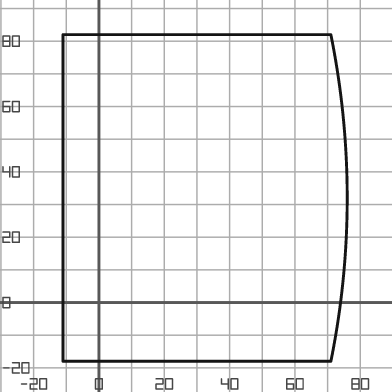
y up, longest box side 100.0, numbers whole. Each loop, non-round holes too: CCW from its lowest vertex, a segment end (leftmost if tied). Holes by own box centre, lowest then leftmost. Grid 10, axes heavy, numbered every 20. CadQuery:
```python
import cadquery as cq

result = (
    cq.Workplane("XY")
    .moveTo(-11.0, -18.0)
    .lineTo(71.0, -18.0)
    .threePointArc((76.0, 32.0), (71.0, 82.0))
    .lineTo(-11.0, 82.0)
    .close()
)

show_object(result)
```